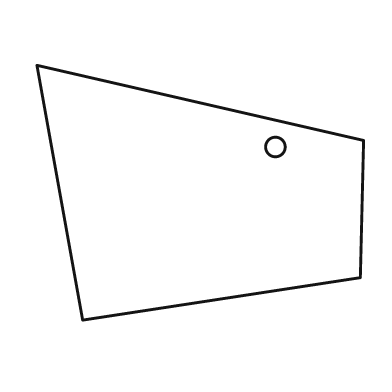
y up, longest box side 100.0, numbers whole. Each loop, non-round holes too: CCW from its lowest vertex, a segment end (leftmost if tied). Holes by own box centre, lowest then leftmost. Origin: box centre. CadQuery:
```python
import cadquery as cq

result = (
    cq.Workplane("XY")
    .moveTo(-36.0, -39.0)
    .lineTo(49.0, -26.0)
    .lineTo(50.0, 16.0)
    .lineTo(-50.0, 39.0)
    .close()
    .moveTo(23.0, 14.0)
    .circle(3.0)
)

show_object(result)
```